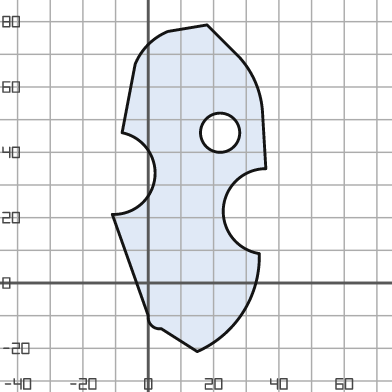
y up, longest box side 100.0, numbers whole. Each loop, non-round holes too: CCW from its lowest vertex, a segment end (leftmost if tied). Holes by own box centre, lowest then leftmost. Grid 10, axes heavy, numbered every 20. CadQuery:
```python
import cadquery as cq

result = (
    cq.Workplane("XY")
    .moveTo(15.0, -21.0)
    .threePointArc((29.0, -9.0), (34.0, 9.0))
    .threePointArc((23.0, 23.0), (36.0, 35.0))
    .lineTo(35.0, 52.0)
    .threePointArc((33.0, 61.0), (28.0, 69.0))
    .lineTo(18.0, 79.0)
    .lineTo(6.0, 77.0)
    .threePointArc((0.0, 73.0), (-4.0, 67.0))
    .lineTo(-8.0, 46.0)
    .threePointArc((2.0, 32.0), (-11.0, 21.0))
    .lineTo(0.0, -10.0)
    .threePointArc((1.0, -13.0), (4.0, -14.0))
    .close()
    .moveTo(22.0, 46.0)
    .circle(6.0)
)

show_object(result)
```